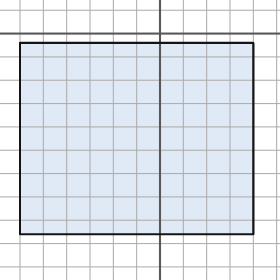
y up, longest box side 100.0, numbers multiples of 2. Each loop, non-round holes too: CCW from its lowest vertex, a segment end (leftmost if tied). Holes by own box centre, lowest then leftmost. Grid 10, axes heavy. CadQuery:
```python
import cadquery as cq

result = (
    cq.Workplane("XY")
    .moveTo(-60.0, -86.0)
    .lineTo(40.0, -86.0)
    .lineTo(40.0, -4.0)
    .lineTo(-60.0, -4.0)
    .close()
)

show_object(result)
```